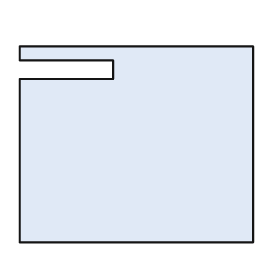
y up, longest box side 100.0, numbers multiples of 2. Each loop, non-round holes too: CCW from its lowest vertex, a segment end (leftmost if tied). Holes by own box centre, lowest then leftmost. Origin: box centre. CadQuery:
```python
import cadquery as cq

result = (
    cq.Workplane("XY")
    .moveTo(-50.0, -42.0)
    .lineTo(50.0, -42.0)
    .lineTo(50.0, 42.0)
    .lineTo(-50.0, 42.0)
    .lineTo(-50.0, 36.0)
    .lineTo(-10.0, 36.0)
    .lineTo(-10.0, 28.0)
    .lineTo(-50.0, 28.0)
    .close()
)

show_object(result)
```